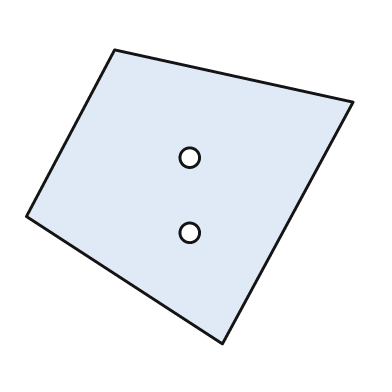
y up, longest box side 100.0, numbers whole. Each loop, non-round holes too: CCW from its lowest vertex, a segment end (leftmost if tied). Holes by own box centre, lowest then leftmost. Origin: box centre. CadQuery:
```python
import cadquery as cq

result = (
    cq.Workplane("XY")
    .moveTo(10.0, -45.0)
    .lineTo(50.0, 29.0)
    .lineTo(-23.0, 45.0)
    .lineTo(-50.0, -6.0)
    .close()
    .moveTo(0.0, -11.0)
    .circle(3.0)
    .moveTo(0.0, 12.0)
    .circle(3.0)
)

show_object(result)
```